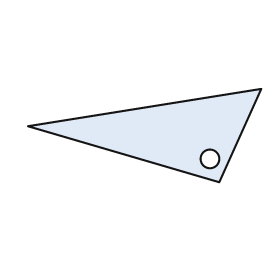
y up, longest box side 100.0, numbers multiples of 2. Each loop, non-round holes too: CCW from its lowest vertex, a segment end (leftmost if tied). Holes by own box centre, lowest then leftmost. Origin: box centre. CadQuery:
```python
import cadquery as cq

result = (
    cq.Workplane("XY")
    .moveTo(32.0, -20.0)
    .lineTo(50.0, 20.0)
    .lineTo(-50.0, 4.0)
    .close()
    .moveTo(28.0, -10.0)
    .circle(4.0)
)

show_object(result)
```